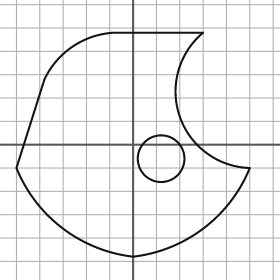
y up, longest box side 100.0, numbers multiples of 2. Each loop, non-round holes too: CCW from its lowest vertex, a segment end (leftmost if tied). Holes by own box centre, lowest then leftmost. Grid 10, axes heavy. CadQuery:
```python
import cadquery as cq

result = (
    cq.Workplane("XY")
    .moveTo(0.0, -48.0)
    .threePointArc((30.0, -36.0), (50.0, -10.0))
    .threePointArc((20.0, 12.0), (30.0, 48.0))
    .lineTo(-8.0, 48.0)
    .threePointArc((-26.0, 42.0), (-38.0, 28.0))
    .lineTo(-50.0, -10.0)
    .threePointArc((-30.0, -36.0), (0.0, -48.0))
    .close()
    .moveTo(12.0, -6.0)
    .circle(10.0)
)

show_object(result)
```